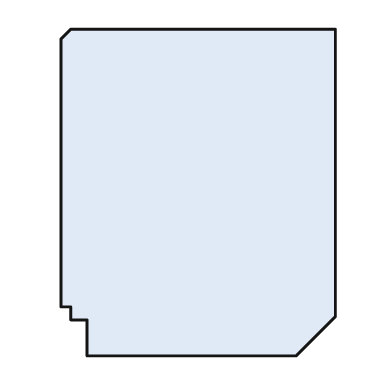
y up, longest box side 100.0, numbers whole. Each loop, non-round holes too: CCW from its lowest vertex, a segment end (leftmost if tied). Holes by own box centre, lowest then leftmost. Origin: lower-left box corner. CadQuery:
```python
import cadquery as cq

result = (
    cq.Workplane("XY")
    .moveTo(8.0, 0.0)
    .lineTo(72.0, 0.0)
    .lineTo(84.0, 12.0)
    .lineTo(84.0, 100.0)
    .lineTo(3.0, 100.0)
    .lineTo(0.0, 97.0)
    .lineTo(0.0, 15.0)
    .lineTo(3.0, 15.0)
    .lineTo(3.0, 11.0)
    .lineTo(8.0, 11.0)
    .close()
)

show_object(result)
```